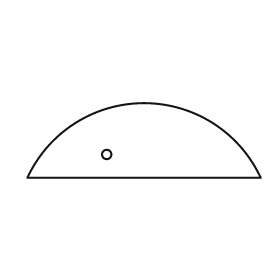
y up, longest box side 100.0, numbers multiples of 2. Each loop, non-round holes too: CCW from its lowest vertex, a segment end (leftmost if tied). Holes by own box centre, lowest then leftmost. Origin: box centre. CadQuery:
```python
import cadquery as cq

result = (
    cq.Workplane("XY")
    .moveTo(-50.0, -16.0)
    .lineTo(50.0, -16.0)
    .threePointArc((0.0, 16.0), (-50.0, -16.0))
    .close()
    .moveTo(-16.0, -6.0)
    .circle(2.0)
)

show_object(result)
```